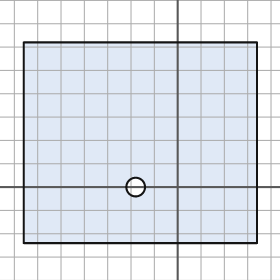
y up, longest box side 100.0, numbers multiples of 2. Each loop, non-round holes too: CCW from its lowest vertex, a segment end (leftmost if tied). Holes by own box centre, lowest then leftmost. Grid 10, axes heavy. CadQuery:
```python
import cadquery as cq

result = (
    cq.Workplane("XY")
    .moveTo(-66.0, -24.0)
    .lineTo(34.0, -24.0)
    .lineTo(34.0, 62.0)
    .lineTo(-66.0, 62.0)
    .close()
    .moveTo(-18.0, 0.0)
    .circle(4.0)
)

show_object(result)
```